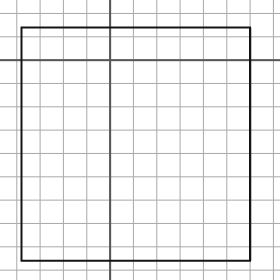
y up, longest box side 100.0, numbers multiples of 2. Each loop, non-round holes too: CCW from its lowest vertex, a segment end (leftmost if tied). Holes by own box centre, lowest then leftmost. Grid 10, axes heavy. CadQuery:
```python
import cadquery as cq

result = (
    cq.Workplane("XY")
    .moveTo(-38.0, -86.0)
    .lineTo(60.0, -86.0)
    .lineTo(60.0, 14.0)
    .lineTo(-38.0, 14.0)
    .close()
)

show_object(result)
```